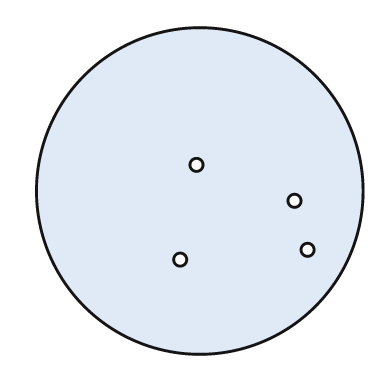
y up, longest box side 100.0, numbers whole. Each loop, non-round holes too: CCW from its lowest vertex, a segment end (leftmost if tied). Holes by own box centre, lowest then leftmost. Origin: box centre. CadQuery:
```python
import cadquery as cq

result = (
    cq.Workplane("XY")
    .moveTo(0.0, 0.0)
    .circle(50.0)
    .moveTo(-6.0, -21.0)
    .circle(2.0)
    .moveTo(33.0, -18.0)
    .circle(2.0)
    .moveTo(29.0, -3.0)
    .circle(2.0)
    .moveTo(-1.0, 8.0)
    .circle(2.0)
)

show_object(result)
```